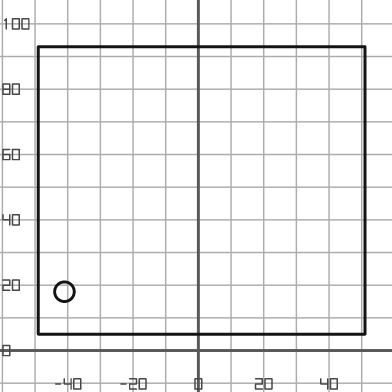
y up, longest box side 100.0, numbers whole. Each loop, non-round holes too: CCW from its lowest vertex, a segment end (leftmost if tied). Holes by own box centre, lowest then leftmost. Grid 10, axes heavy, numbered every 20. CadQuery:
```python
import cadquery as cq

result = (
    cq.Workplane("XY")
    .moveTo(-49.0, 5.0)
    .lineTo(51.0, 5.0)
    .lineTo(51.0, 93.0)
    .lineTo(-49.0, 93.0)
    .close()
    .moveTo(-41.0, 18.0)
    .circle(3.0)
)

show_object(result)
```